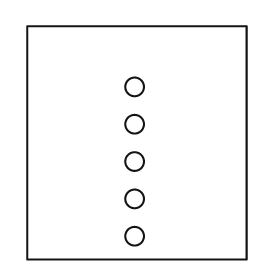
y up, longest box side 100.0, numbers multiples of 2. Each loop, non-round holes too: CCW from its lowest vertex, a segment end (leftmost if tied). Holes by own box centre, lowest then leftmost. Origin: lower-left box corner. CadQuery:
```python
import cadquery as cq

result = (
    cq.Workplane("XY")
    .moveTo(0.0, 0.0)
    .lineTo(94.0, 0.0)
    .lineTo(94.0, 100.0)
    .lineTo(0.0, 100.0)
    .close()
    .moveTo(46.0, 10.0)
    .circle(4.0)
    .moveTo(46.0, 26.0)
    .circle(4.0)
    .moveTo(46.0, 42.0)
    .circle(4.0)
    .moveTo(46.0, 58.0)
    .circle(4.0)
    .moveTo(46.0, 74.0)
    .circle(4.0)
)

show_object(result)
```